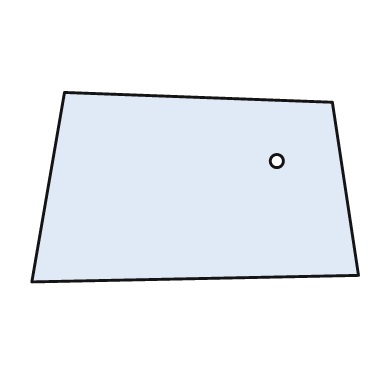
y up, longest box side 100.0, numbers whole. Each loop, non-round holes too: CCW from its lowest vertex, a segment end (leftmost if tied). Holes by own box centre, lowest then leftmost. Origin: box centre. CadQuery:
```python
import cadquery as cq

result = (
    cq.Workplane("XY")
    .moveTo(-50.0, -29.0)
    .lineTo(50.0, -27.0)
    .lineTo(42.0, 26.0)
    .lineTo(-40.0, 29.0)
    .close()
    .moveTo(25.0, 8.0)
    .circle(2.0)
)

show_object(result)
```